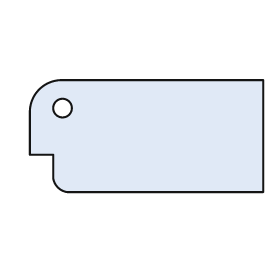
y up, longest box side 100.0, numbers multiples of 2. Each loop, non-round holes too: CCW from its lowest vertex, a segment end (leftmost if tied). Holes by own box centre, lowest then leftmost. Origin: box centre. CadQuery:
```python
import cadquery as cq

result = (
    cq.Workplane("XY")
    .moveTo(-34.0, -24.0)
    .lineTo(50.0, -24.0)
    .lineTo(50.0, 24.0)
    .lineTo(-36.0, 24.0)
    .threePointArc((-46.0, 20.0), (-50.0, 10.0))
    .lineTo(-50.0, -8.0)
    .lineTo(-40.0, -8.0)
    .lineTo(-40.0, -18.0)
    .threePointArc((-38.0, -22.0), (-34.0, -24.0))
    .close()
    .moveTo(-36.0, 12.0)
    .circle(4.0)
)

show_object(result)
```